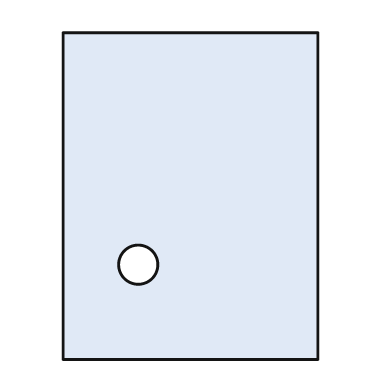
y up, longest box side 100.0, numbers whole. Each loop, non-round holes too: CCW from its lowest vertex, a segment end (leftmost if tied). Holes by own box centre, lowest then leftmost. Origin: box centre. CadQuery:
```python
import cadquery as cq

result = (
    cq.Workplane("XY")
    .moveTo(-39.0, -50.0)
    .lineTo(39.0, -50.0)
    .lineTo(39.0, 50.0)
    .lineTo(-39.0, 50.0)
    .close()
    .moveTo(-16.0, -21.0)
    .circle(6.0)
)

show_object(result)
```